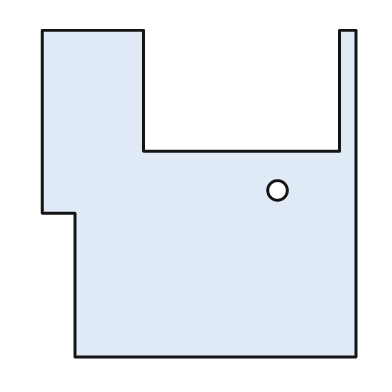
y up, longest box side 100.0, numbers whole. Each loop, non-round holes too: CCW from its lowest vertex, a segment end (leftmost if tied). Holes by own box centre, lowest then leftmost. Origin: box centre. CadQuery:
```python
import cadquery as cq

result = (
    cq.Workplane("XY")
    .moveTo(-38.0, -50.0)
    .lineTo(48.0, -50.0)
    .lineTo(48.0, 50.0)
    .lineTo(43.0, 50.0)
    .lineTo(43.0, 13.0)
    .lineTo(-17.0, 13.0)
    .lineTo(-17.0, 50.0)
    .lineTo(-48.0, 50.0)
    .lineTo(-48.0, -6.0)
    .lineTo(-38.0, -6.0)
    .close()
    .moveTo(24.0, 1.0)
    .circle(3.0)
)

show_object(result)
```